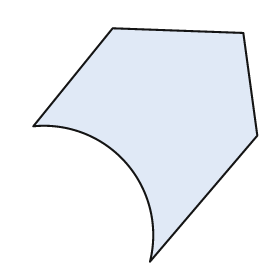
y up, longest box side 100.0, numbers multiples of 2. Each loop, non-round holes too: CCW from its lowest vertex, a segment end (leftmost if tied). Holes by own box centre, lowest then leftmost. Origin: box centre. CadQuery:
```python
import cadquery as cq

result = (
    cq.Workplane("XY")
    .moveTo(2.0, -50.0)
    .lineTo(48.0, 4.0)
    .lineTo(42.0, 48.0)
    .lineTo(-14.0, 50.0)
    .lineTo(-48.0, 8.0)
    .threePointArc((-8.0, -8.0), (2.0, -50.0))
    .close()
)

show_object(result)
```